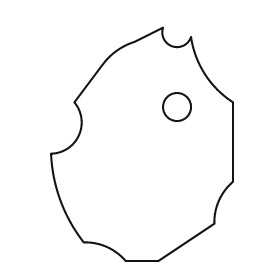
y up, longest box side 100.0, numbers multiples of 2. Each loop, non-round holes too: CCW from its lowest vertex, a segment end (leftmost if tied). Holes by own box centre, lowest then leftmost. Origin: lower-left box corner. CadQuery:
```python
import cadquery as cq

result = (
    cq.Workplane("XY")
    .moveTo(32.0, 0.0)
    .lineTo(46.0, 0.0)
    .lineTo(70.0, 16.0)
    .threePointArc((72.0, 26.0), (78.0, 34.0))
    .lineTo(78.0, 68.0)
    .threePointArc((66.0, 80.0), (60.0, 96.0))
    .threePointArc((52.0, 92.0), (48.0, 100.0))
    .lineTo(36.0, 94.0)
    .threePointArc((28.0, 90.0), (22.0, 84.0))
    .lineTo(10.0, 68.0)
    .threePointArc((12.0, 54.0), (0.0, 46.0))
    .threePointArc((4.0, 26.0), (14.0, 8.0))
    .threePointArc((24.0, 6.0), (32.0, 0.0))
    .close()
    .moveTo(54.0, 66.0)
    .circle(6.0)
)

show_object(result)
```